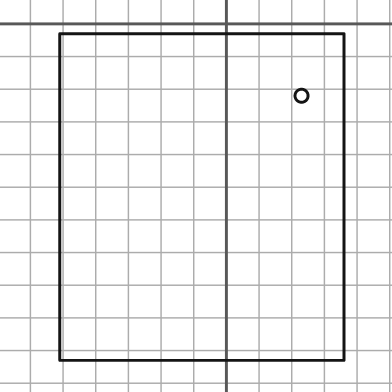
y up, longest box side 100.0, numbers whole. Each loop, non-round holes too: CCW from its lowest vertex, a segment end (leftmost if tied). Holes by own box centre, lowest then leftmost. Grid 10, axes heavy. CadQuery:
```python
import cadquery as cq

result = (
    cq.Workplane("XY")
    .moveTo(-51.0, -103.0)
    .lineTo(36.0, -103.0)
    .lineTo(36.0, -3.0)
    .lineTo(-51.0, -3.0)
    .close()
    .moveTo(23.0, -22.0)
    .circle(2.0)
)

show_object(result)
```